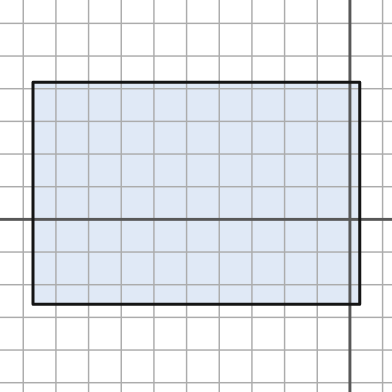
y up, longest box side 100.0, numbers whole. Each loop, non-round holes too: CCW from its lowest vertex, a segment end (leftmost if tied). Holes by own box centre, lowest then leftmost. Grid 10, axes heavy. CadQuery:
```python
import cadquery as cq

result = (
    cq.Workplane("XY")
    .moveTo(-97.0, -26.0)
    .lineTo(3.0, -26.0)
    .lineTo(3.0, 42.0)
    .lineTo(-97.0, 42.0)
    .close()
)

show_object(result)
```